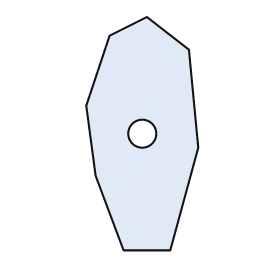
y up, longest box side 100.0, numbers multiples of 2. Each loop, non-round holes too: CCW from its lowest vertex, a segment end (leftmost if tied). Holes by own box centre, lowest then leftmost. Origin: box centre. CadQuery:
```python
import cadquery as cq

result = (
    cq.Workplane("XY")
    .moveTo(-8.0, -50.0)
    .lineTo(12.0, -50.0)
    .lineTo(24.0, -6.0)
    .lineTo(20.0, 36.0)
    .lineTo(2.0, 50.0)
    .lineTo(-14.0, 42.0)
    .lineTo(-24.0, 12.0)
    .lineTo(-20.0, -18.0)
    .close()
    .moveTo(0.0, 0.0)
    .circle(6.0)
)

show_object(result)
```